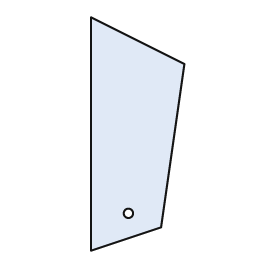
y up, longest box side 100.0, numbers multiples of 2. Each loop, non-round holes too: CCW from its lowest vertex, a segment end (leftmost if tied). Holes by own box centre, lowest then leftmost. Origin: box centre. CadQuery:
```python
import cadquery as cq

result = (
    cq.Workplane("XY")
    .moveTo(-20.0, -50.0)
    .lineTo(10.0, -40.0)
    .lineTo(20.0, 30.0)
    .lineTo(-20.0, 50.0)
    .close()
    .moveTo(-4.0, -34.0)
    .circle(2.0)
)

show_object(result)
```